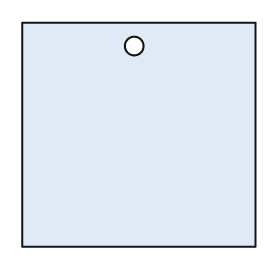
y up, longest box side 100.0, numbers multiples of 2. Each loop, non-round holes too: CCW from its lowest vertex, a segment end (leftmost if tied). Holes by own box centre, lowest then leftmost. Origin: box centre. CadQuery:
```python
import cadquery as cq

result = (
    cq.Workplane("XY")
    .moveTo(-50.0, -48.0)
    .lineTo(50.0, -48.0)
    .lineTo(50.0, 48.0)
    .lineTo(-50.0, 48.0)
    .close()
    .moveTo(-2.0, 38.0)
    .circle(4.0)
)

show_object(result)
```